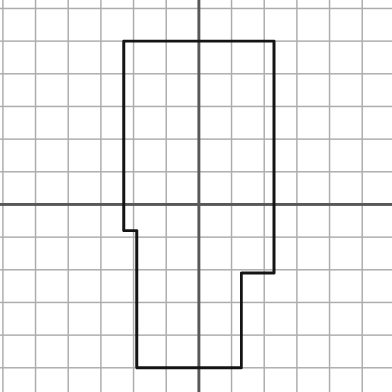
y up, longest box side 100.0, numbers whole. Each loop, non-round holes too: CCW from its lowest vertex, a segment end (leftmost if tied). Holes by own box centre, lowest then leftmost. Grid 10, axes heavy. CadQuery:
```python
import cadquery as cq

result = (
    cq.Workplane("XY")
    .moveTo(-19.0, -50.0)
    .lineTo(13.0, -50.0)
    .lineTo(13.0, -21.0)
    .lineTo(23.0, -21.0)
    .lineTo(23.0, 50.0)
    .lineTo(-23.0, 50.0)
    .lineTo(-23.0, -8.0)
    .lineTo(-19.0, -8.0)
    .close()
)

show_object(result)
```